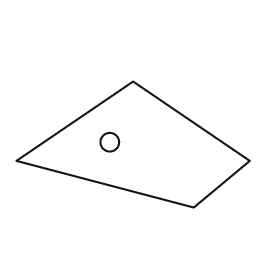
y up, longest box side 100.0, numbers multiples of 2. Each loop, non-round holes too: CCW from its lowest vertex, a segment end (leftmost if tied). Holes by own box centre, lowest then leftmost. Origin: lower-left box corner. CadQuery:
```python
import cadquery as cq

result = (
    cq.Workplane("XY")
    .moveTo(76.0, 0.0)
    .lineTo(100.0, 20.0)
    .lineTo(50.0, 54.0)
    .lineTo(0.0, 20.0)
    .close()
    .moveTo(40.0, 28.0)
    .circle(4.0)
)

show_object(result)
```